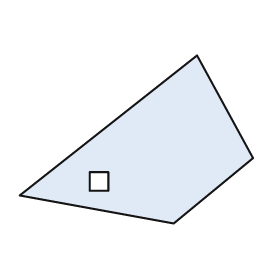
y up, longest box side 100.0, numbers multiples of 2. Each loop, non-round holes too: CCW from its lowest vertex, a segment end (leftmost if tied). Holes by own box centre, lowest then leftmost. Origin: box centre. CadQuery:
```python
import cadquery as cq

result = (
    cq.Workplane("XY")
    .moveTo(16.0, -36.0)
    .lineTo(50.0, -8.0)
    .lineTo(26.0, 36.0)
    .lineTo(-50.0, -24.0)
    .close()
    .moveTo(-20.0, -22.0)
    .lineTo(-12.0, -22.0)
    .lineTo(-12.0, -14.0)
    .lineTo(-20.0, -14.0)
    .close()
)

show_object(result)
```